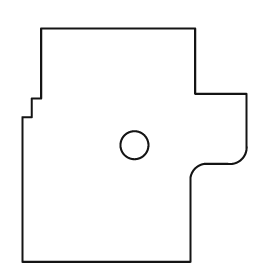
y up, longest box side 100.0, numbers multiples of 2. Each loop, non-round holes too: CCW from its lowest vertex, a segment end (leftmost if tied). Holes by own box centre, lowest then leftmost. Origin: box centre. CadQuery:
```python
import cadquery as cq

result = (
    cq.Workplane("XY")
    .moveTo(-48.0, -50.0)
    .lineTo(24.0, -50.0)
    .lineTo(24.0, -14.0)
    .threePointArc((26.0, -10.0), (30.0, -8.0))
    .lineTo(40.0, -8.0)
    .threePointArc((46.0, -6.0), (48.0, 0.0))
    .lineTo(48.0, 22.0)
    .lineTo(26.0, 22.0)
    .lineTo(26.0, 50.0)
    .lineTo(-40.0, 50.0)
    .lineTo(-40.0, 20.0)
    .lineTo(-44.0, 20.0)
    .lineTo(-44.0, 12.0)
    .lineTo(-48.0, 12.0)
    .close()
    .moveTo(0.0, 0.0)
    .circle(6.0)
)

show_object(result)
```